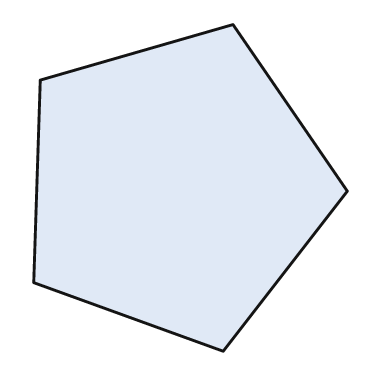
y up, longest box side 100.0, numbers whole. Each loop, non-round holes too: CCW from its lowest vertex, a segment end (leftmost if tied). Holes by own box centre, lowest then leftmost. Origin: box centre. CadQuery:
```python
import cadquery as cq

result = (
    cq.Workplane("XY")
    .moveTo(10.0, -50.0)
    .lineTo(48.0, -1.0)
    .lineTo(13.0, 50.0)
    .lineTo(-46.0, 33.0)
    .lineTo(-48.0, -29.0)
    .close()
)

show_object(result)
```